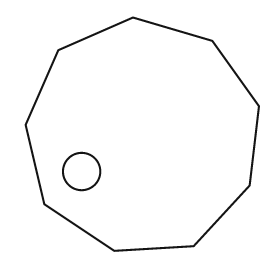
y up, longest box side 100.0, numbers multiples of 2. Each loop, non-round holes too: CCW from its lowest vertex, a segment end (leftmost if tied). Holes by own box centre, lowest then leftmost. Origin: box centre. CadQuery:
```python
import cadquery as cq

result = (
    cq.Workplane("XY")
    .moveTo(-12.0, -50.0)
    .lineTo(22.0, -48.0)
    .lineTo(46.0, -22.0)
    .lineTo(50.0, 12.0)
    .lineTo(30.0, 40.0)
    .lineTo(-4.0, 50.0)
    .lineTo(-36.0, 36.0)
    .lineTo(-50.0, 4.0)
    .lineTo(-42.0, -30.0)
    .close()
    .moveTo(-26.0, -16.0)
    .circle(8.0)
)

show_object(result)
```